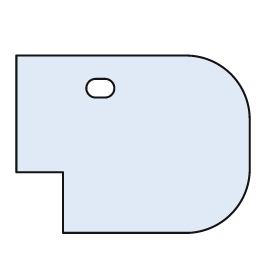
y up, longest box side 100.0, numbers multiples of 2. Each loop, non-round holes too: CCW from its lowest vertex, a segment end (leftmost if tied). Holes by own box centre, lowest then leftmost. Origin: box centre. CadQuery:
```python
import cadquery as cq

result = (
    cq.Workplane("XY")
    .moveTo(-30.0, -38.0)
    .lineTo(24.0, -38.0)
    .threePointArc((42.0, -30.0), (50.0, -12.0))
    .lineTo(50.0, 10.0)
    .threePointArc((42.0, 30.0), (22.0, 38.0))
    .lineTo(-50.0, 38.0)
    .lineTo(-50.0, -12.0)
    .lineTo(-30.0, -12.0)
    .close()
    .moveTo(-16.0, 20.0)
    .lineTo(-12.0, 20.0)
    .threePointArc((-8.0, 24.0), (-12.0, 28.0))
    .lineTo(-16.0, 28.0)
    .threePointArc((-20.0, 24.0), (-16.0, 20.0))
    .close()
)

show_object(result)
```